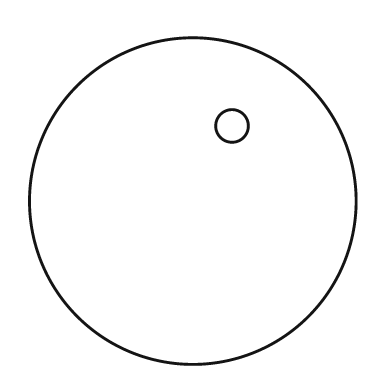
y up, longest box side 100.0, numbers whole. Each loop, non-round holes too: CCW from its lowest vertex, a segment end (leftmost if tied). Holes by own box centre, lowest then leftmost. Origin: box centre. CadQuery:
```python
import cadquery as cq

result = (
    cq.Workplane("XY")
    .moveTo(0.0, 0.0)
    .circle(50.0)
    .moveTo(12.0, 23.0)
    .circle(5.0)
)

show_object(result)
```